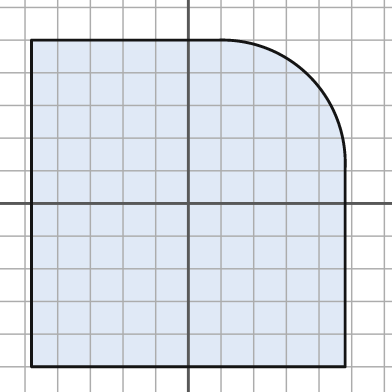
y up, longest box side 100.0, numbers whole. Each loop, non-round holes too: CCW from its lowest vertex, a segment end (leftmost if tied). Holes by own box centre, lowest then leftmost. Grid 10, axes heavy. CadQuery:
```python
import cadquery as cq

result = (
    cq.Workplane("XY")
    .moveTo(-48.0, -50.0)
    .lineTo(48.0, -50.0)
    .lineTo(48.0, 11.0)
    .threePointArc((37.0, 39.0), (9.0, 50.0))
    .lineTo(-48.0, 50.0)
    .close()
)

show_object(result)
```